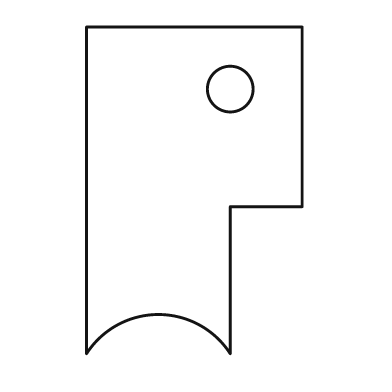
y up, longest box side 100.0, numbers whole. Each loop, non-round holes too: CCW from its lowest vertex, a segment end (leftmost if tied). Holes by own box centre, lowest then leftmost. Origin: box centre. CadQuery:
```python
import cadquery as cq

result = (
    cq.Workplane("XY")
    .moveTo(-33.0, -50.0)
    .threePointArc((-11.0, -38.0), (11.0, -50.0))
    .lineTo(11.0, -5.0)
    .lineTo(33.0, -5.0)
    .lineTo(33.0, 50.0)
    .lineTo(-33.0, 50.0)
    .close()
    .moveTo(11.0, 31.0)
    .circle(7.0)
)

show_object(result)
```